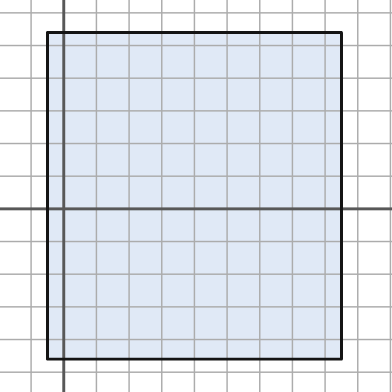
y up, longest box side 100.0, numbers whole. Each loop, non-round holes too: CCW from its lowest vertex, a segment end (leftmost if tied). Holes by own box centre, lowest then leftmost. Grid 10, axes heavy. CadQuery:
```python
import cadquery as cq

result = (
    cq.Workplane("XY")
    .moveTo(-5.0, -46.0)
    .lineTo(85.0, -46.0)
    .lineTo(85.0, 54.0)
    .lineTo(-5.0, 54.0)
    .close()
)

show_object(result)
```